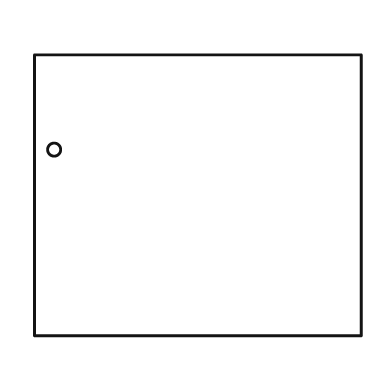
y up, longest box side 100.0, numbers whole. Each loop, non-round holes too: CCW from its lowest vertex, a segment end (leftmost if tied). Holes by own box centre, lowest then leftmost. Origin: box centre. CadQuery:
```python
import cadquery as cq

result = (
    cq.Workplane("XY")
    .moveTo(-50.0, -43.0)
    .lineTo(50.0, -43.0)
    .lineTo(50.0, 43.0)
    .lineTo(-50.0, 43.0)
    .close()
    .moveTo(-44.0, 14.0)
    .circle(2.0)
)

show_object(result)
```